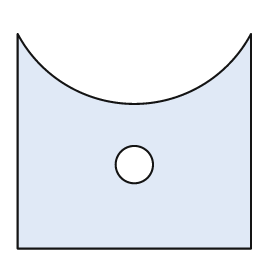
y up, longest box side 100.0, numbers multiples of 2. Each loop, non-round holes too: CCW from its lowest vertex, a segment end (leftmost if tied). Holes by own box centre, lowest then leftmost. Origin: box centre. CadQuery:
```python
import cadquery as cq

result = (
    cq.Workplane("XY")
    .moveTo(-50.0, -46.0)
    .lineTo(50.0, -46.0)
    .lineTo(50.0, 46.0)
    .threePointArc((0.0, 16.0), (-50.0, 46.0))
    .close()
    .moveTo(0.0, -10.0)
    .circle(8.0)
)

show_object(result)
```